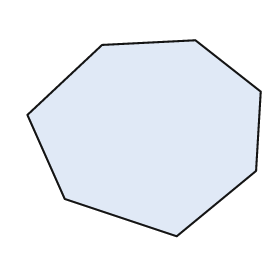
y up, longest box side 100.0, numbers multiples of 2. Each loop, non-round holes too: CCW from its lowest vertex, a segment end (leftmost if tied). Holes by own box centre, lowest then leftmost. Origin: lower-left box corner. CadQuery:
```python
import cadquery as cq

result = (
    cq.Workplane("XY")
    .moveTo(64.0, 0.0)
    .lineTo(98.0, 28.0)
    .lineTo(100.0, 62.0)
    .lineTo(72.0, 84.0)
    .lineTo(32.0, 82.0)
    .lineTo(0.0, 52.0)
    .lineTo(16.0, 16.0)
    .close()
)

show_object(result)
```